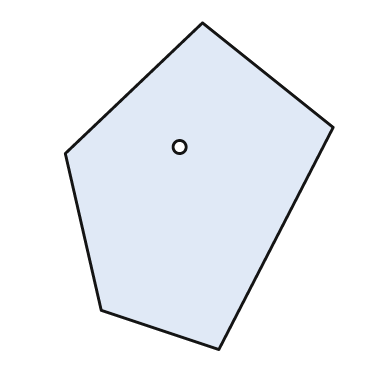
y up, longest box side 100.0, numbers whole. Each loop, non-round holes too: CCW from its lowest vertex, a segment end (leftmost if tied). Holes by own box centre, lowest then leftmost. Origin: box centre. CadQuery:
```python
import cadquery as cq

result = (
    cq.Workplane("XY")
    .moveTo(6.0, -50.0)
    .lineTo(41.0, 18.0)
    .lineTo(1.0, 50.0)
    .lineTo(-41.0, 10.0)
    .lineTo(-30.0, -38.0)
    .close()
    .moveTo(-6.0, 12.0)
    .circle(2.0)
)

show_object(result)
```